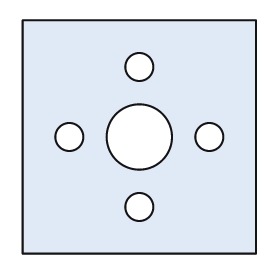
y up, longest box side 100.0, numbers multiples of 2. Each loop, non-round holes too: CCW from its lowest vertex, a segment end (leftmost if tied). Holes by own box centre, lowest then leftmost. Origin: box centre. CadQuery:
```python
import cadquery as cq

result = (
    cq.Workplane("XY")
    .moveTo(-50.0, -50.0)
    .lineTo(50.0, -50.0)
    .lineTo(50.0, 50.0)
    .lineTo(-50.0, 50.0)
    .close()
    .moveTo(0.0, -30.0)
    .circle(6.0)
    .moveTo(-30.0, 0.0)
    .circle(6.0)
    .moveTo(0.0, 0.0)
    .circle(14.0)
    .moveTo(30.0, 0.0)
    .circle(6.0)
    .moveTo(0.0, 30.0)
    .circle(6.0)
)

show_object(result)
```